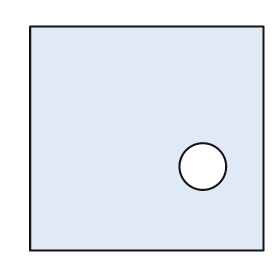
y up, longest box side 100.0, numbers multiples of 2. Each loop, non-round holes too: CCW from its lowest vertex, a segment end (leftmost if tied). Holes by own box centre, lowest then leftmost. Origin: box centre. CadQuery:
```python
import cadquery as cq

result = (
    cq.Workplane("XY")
    .moveTo(-50.0, -48.0)
    .lineTo(50.0, -48.0)
    .lineTo(50.0, 48.0)
    .lineTo(-50.0, 48.0)
    .close()
    .moveTo(24.0, -12.0)
    .circle(10.0)
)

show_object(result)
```